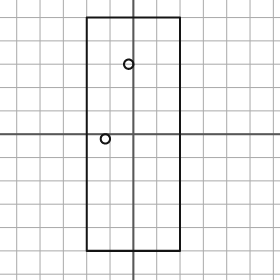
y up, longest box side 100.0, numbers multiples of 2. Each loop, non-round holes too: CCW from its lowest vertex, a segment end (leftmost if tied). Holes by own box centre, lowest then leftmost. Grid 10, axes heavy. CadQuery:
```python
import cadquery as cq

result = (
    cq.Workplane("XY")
    .moveTo(-20.0, -50.0)
    .lineTo(20.0, -50.0)
    .lineTo(20.0, 50.0)
    .lineTo(-20.0, 50.0)
    .close()
    .moveTo(-12.0, -2.0)
    .circle(2.0)
    .moveTo(-2.0, 30.0)
    .circle(2.0)
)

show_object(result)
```